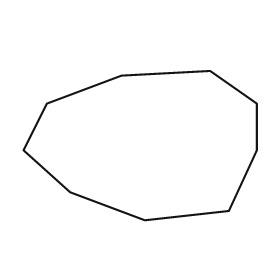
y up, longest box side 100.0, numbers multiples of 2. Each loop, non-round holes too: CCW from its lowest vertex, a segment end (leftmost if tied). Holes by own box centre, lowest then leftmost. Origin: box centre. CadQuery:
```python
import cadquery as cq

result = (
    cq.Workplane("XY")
    .moveTo(2.0, -32.0)
    .lineTo(38.0, -28.0)
    .lineTo(50.0, -2.0)
    .lineTo(50.0, 18.0)
    .lineTo(30.0, 32.0)
    .lineTo(-8.0, 30.0)
    .lineTo(-40.0, 18.0)
    .lineTo(-50.0, -2.0)
    .lineTo(-30.0, -20.0)
    .close()
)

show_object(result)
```